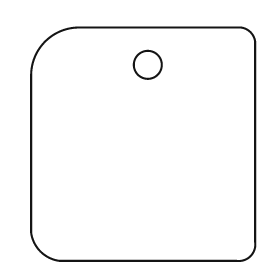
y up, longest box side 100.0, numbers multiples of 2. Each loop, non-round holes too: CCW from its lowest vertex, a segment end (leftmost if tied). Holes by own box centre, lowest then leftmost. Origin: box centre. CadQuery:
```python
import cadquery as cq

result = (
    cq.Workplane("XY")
    .moveTo(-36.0, -50.0)
    .lineTo(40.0, -50.0)
    .threePointArc((46.0, -48.0), (48.0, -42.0))
    .lineTo(48.0, 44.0)
    .threePointArc((46.0, 48.0), (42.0, 50.0))
    .lineTo(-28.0, 50.0)
    .threePointArc((-42.0, 44.0), (-48.0, 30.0))
    .lineTo(-48.0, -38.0)
    .threePointArc((-44.0, -46.0), (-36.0, -50.0))
    .close()
    .moveTo(2.0, 34.0)
    .circle(6.0)
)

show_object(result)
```